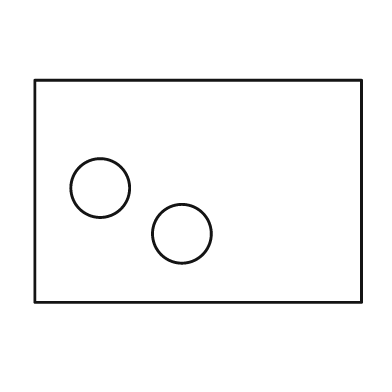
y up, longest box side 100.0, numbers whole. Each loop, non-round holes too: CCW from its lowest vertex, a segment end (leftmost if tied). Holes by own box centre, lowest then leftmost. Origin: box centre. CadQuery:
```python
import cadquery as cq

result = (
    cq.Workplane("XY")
    .moveTo(-50.0, -34.0)
    .lineTo(50.0, -34.0)
    .lineTo(50.0, 34.0)
    .lineTo(-50.0, 34.0)
    .close()
    .moveTo(-5.0, -13.0)
    .circle(9.0)
    .moveTo(-30.0, 1.0)
    .circle(9.0)
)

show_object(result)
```